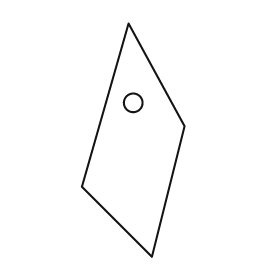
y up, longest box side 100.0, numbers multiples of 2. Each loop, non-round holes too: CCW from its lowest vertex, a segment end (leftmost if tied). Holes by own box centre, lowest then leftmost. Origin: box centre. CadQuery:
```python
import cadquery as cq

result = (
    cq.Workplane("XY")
    .moveTo(8.0, -50.0)
    .lineTo(22.0, 6.0)
    .lineTo(-2.0, 50.0)
    .lineTo(-22.0, -20.0)
    .close()
    .moveTo(0.0, 16.0)
    .circle(4.0)
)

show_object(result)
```